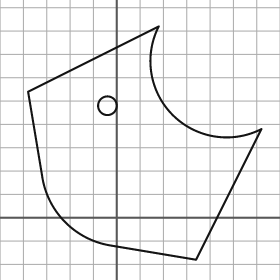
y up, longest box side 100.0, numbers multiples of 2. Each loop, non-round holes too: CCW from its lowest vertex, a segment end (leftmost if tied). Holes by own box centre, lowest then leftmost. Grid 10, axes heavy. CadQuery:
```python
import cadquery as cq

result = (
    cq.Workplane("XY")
    .moveTo(34.0, -18.0)
    .lineTo(62.0, 38.0)
    .threePointArc((24.0, 44.0), (18.0, 82.0))
    .lineTo(-38.0, 54.0)
    .lineTo(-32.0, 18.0)
    .threePointArc((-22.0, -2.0), (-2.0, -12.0))
    .close()
    .moveTo(-4.0, 48.0)
    .circle(4.0)
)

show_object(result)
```